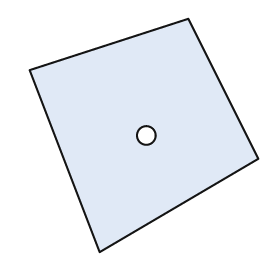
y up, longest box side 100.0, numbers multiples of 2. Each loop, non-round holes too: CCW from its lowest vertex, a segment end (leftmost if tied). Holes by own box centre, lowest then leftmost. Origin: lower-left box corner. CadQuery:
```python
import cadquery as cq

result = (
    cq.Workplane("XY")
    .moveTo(30.0, 0.0)
    .lineTo(98.0, 40.0)
    .lineTo(68.0, 100.0)
    .lineTo(0.0, 78.0)
    .close()
    .moveTo(50.0, 50.0)
    .circle(4.0)
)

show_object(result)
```